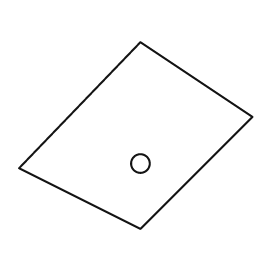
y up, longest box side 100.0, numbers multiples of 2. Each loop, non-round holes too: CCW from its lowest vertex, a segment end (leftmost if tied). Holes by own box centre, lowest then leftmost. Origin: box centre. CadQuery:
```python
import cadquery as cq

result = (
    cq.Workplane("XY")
    .moveTo(2.0, -40.0)
    .lineTo(50.0, 8.0)
    .lineTo(2.0, 40.0)
    .lineTo(-50.0, -14.0)
    .close()
    .moveTo(2.0, -12.0)
    .circle(4.0)
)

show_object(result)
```